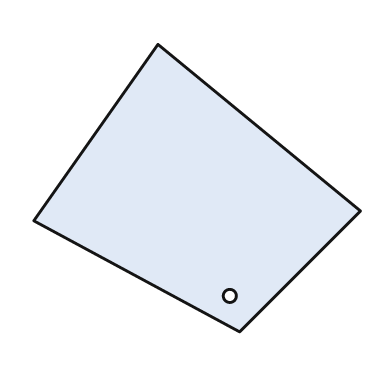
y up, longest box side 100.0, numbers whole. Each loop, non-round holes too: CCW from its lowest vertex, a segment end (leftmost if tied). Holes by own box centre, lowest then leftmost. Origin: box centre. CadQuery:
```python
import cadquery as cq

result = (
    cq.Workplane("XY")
    .moveTo(13.0, -44.0)
    .lineTo(50.0, -7.0)
    .lineTo(-12.0, 44.0)
    .lineTo(-50.0, -10.0)
    .close()
    .moveTo(10.0, -33.0)
    .circle(2.0)
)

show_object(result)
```